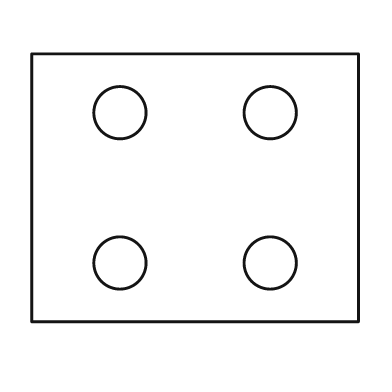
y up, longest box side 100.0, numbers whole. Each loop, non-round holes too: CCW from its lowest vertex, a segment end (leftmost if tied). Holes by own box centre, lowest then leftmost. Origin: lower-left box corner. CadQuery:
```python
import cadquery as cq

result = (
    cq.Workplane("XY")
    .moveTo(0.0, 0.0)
    .lineTo(100.0, 0.0)
    .lineTo(100.0, 82.0)
    .lineTo(0.0, 82.0)
    .close()
    .moveTo(27.0, 18.0)
    .circle(8.0)
    .moveTo(73.0, 18.0)
    .circle(8.0)
    .moveTo(27.0, 64.0)
    .circle(8.0)
    .moveTo(73.0, 64.0)
    .circle(8.0)
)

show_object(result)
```